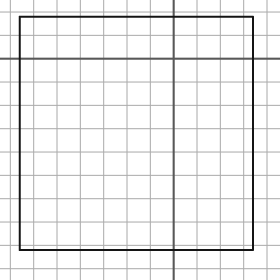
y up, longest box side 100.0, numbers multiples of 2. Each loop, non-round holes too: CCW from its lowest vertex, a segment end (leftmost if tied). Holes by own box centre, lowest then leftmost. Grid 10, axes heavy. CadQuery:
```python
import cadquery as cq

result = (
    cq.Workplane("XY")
    .moveTo(-66.0, -82.0)
    .lineTo(34.0, -82.0)
    .lineTo(34.0, 18.0)
    .lineTo(-66.0, 18.0)
    .close()
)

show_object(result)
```